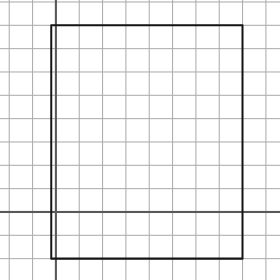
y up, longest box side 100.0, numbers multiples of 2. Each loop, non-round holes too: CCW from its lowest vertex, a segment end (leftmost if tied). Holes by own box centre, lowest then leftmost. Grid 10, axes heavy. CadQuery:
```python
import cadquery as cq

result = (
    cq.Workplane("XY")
    .moveTo(-2.0, -20.0)
    .lineTo(80.0, -20.0)
    .lineTo(80.0, 80.0)
    .lineTo(-2.0, 80.0)
    .close()
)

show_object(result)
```